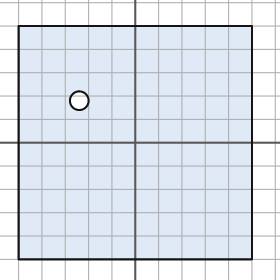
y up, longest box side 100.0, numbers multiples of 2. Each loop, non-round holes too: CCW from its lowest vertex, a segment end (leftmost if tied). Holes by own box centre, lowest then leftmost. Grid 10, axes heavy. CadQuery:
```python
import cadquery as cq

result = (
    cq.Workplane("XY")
    .moveTo(-50.0, -50.0)
    .lineTo(50.0, -50.0)
    .lineTo(50.0, 50.0)
    .lineTo(-50.0, 50.0)
    .close()
    .moveTo(-24.0, 18.0)
    .circle(4.0)
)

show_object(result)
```